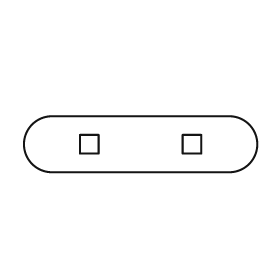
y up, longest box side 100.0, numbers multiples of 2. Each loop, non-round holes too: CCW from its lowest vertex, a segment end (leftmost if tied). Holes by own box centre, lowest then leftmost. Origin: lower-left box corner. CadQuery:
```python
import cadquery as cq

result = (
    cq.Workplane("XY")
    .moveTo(12.0, 0.0)
    .lineTo(88.0, 0.0)
    .threePointArc((100.0, 12.0), (88.0, 24.0))
    .lineTo(12.0, 24.0)
    .threePointArc((0.0, 12.0), (12.0, 0.0))
    .close()
    .moveTo(24.0, 8.0)
    .lineTo(32.0, 8.0)
    .lineTo(32.0, 16.0)
    .lineTo(24.0, 16.0)
    .close()
    .moveTo(68.0, 8.0)
    .lineTo(76.0, 8.0)
    .lineTo(76.0, 16.0)
    .lineTo(68.0, 16.0)
    .close()
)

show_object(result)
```